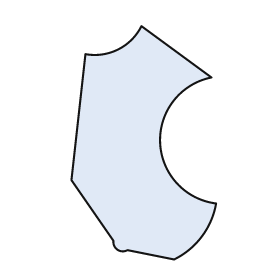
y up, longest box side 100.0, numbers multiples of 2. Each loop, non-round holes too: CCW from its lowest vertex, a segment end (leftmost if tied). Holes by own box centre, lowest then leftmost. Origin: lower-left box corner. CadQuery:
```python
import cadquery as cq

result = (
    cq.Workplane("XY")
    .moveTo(44.0, 0.0)
    .threePointArc((56.0, 10.0), (62.0, 24.0))
    .threePointArc((38.0, 50.0), (60.0, 78.0))
    .lineTo(30.0, 100.0)
    .threePointArc((20.0, 90.0), (6.0, 88.0))
    .lineTo(0.0, 34.0)
    .lineTo(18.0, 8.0)
    .threePointArc((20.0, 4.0), (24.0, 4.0))
    .close()
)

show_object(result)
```